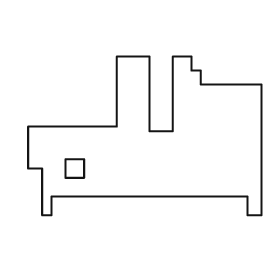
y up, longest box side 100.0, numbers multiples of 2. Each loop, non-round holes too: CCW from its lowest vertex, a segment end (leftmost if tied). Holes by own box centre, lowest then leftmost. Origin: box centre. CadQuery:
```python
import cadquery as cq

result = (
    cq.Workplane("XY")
    .moveTo(-44.0, -34.0)
    .lineTo(-40.0, -34.0)
    .lineTo(-40.0, -26.0)
    .lineTo(44.0, -26.0)
    .lineTo(44.0, -34.0)
    .lineTo(50.0, -34.0)
    .lineTo(50.0, 22.0)
    .lineTo(24.0, 22.0)
    .lineTo(24.0, 28.0)
    .lineTo(20.0, 28.0)
    .lineTo(20.0, 34.0)
    .lineTo(12.0, 34.0)
    .lineTo(12.0, 2.0)
    .lineTo(2.0, 2.0)
    .lineTo(2.0, 34.0)
    .lineTo(-12.0, 34.0)
    .lineTo(-12.0, 4.0)
    .lineTo(-50.0, 4.0)
    .lineTo(-50.0, -14.0)
    .lineTo(-44.0, -14.0)
    .close()
    .moveTo(-34.0, -18.0)
    .lineTo(-26.0, -18.0)
    .lineTo(-26.0, -10.0)
    .lineTo(-34.0, -10.0)
    .close()
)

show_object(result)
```